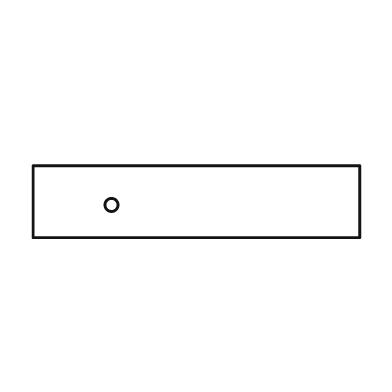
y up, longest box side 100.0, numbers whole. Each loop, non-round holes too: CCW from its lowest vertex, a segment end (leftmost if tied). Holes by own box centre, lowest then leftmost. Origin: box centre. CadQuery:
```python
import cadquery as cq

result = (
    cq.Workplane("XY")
    .moveTo(-50.0, -11.0)
    .lineTo(50.0, -11.0)
    .lineTo(50.0, 11.0)
    .lineTo(-50.0, 11.0)
    .close()
    .moveTo(-26.0, -1.0)
    .circle(2.0)
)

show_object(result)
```